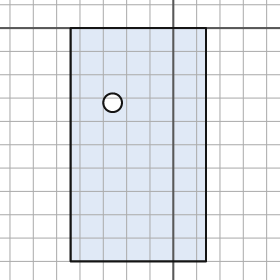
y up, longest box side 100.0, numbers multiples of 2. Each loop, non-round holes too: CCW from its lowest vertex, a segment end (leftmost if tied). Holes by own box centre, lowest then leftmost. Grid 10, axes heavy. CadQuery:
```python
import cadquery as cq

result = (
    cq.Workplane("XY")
    .moveTo(-44.0, -100.0)
    .lineTo(14.0, -100.0)
    .lineTo(14.0, 0.0)
    .lineTo(-44.0, 0.0)
    .close()
    .moveTo(-26.0, -32.0)
    .circle(4.0)
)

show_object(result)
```